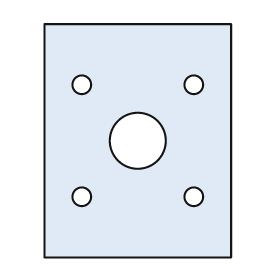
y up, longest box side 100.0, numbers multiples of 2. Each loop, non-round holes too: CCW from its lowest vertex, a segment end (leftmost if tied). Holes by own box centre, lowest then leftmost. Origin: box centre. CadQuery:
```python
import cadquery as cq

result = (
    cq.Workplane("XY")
    .moveTo(-40.0, -50.0)
    .lineTo(40.0, -50.0)
    .lineTo(40.0, 50.0)
    .lineTo(-40.0, 50.0)
    .close()
    .moveTo(-24.0, -24.0)
    .circle(4.0)
    .moveTo(24.0, -24.0)
    .circle(4.0)
    .moveTo(0.0, 0.0)
    .circle(12.0)
    .moveTo(-24.0, 24.0)
    .circle(4.0)
    .moveTo(24.0, 24.0)
    .circle(4.0)
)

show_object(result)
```